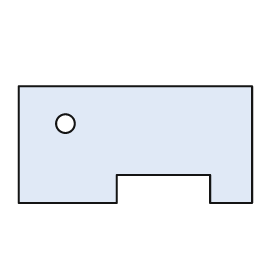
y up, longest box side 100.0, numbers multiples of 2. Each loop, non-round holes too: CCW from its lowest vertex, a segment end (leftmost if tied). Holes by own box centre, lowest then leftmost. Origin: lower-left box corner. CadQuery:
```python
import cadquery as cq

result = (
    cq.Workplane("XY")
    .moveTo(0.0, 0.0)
    .lineTo(42.0, 0.0)
    .lineTo(42.0, 12.0)
    .lineTo(82.0, 12.0)
    .lineTo(82.0, 0.0)
    .lineTo(100.0, 0.0)
    .lineTo(100.0, 50.0)
    .lineTo(0.0, 50.0)
    .close()
    .moveTo(20.0, 34.0)
    .circle(4.0)
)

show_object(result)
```